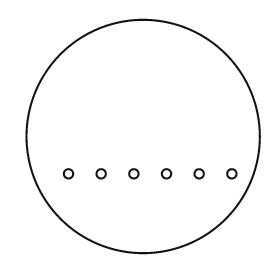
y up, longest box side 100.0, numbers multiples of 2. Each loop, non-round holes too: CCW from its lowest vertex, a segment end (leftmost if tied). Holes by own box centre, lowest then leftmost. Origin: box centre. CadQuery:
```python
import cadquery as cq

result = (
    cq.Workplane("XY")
    .moveTo(0.0, 0.0)
    .circle(50.0)
    .moveTo(-32.0, -16.0)
    .circle(2.0)
    .moveTo(-18.0, -16.0)
    .circle(2.0)
    .moveTo(-4.0, -16.0)
    .circle(2.0)
    .moveTo(10.0, -16.0)
    .circle(2.0)
    .moveTo(24.0, -16.0)
    .circle(2.0)
    .moveTo(38.0, -16.0)
    .circle(2.0)
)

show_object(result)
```